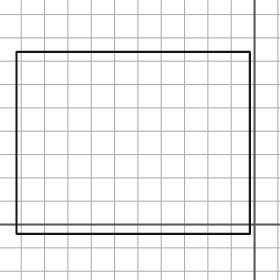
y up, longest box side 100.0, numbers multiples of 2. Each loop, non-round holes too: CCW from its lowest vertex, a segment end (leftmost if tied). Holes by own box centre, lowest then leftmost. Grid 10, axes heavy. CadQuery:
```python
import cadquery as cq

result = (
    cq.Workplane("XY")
    .moveTo(-102.0, -4.0)
    .lineTo(-2.0, -4.0)
    .lineTo(-2.0, 74.0)
    .lineTo(-102.0, 74.0)
    .close()
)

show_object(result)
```